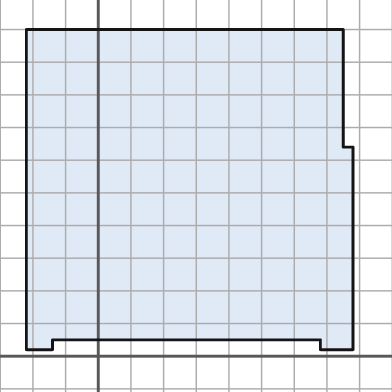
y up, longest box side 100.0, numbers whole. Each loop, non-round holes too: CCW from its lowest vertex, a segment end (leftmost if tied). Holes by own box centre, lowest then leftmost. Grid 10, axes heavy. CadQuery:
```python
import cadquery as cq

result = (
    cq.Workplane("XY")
    .moveTo(-22.0, 2.0)
    .lineTo(-14.0, 2.0)
    .lineTo(-14.0, 5.0)
    .lineTo(68.0, 5.0)
    .lineTo(68.0, 2.0)
    .lineTo(78.0, 2.0)
    .lineTo(78.0, 64.0)
    .lineTo(75.0, 64.0)
    .lineTo(75.0, 100.0)
    .lineTo(-22.0, 100.0)
    .close()
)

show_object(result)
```